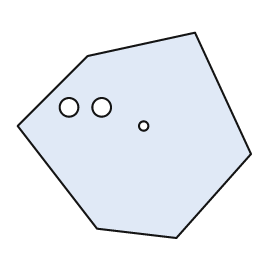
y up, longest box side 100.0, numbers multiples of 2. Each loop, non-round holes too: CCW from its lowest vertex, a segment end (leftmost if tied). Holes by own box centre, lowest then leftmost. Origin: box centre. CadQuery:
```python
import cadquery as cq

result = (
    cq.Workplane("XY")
    .moveTo(18.0, -44.0)
    .lineTo(50.0, -8.0)
    .lineTo(26.0, 44.0)
    .lineTo(-20.0, 34.0)
    .lineTo(-50.0, 4.0)
    .lineTo(-16.0, -40.0)
    .close()
    .moveTo(4.0, 4.0)
    .circle(2.0)
    .moveTo(-28.0, 12.0)
    .circle(4.0)
    .moveTo(-14.0, 12.0)
    .circle(4.0)
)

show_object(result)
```